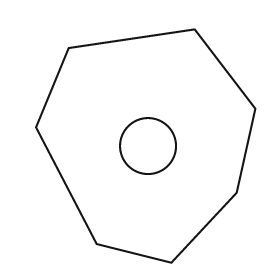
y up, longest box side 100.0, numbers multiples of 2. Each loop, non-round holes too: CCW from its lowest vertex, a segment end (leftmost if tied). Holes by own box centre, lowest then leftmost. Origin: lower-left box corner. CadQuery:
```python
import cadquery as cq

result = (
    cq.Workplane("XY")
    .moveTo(58.0, 0.0)
    .lineTo(86.0, 30.0)
    .lineTo(94.0, 66.0)
    .lineTo(68.0, 100.0)
    .lineTo(14.0, 92.0)
    .lineTo(0.0, 58.0)
    .lineTo(26.0, 8.0)
    .close()
    .moveTo(48.0, 50.0)
    .circle(12.0)
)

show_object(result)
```